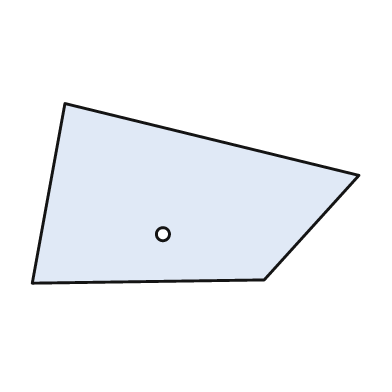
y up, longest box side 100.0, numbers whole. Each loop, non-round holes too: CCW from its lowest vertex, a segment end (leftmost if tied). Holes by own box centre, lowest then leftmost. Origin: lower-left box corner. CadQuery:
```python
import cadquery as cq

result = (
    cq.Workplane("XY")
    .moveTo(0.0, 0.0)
    .lineTo(71.0, 1.0)
    .lineTo(100.0, 33.0)
    .lineTo(10.0, 55.0)
    .close()
    .moveTo(40.0, 15.0)
    .circle(2.0)
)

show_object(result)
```